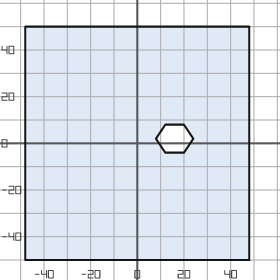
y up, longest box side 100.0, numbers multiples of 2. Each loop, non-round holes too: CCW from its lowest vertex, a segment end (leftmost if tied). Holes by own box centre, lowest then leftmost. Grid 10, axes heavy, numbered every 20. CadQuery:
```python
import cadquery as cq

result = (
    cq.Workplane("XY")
    .moveTo(-48.0, -50.0)
    .lineTo(48.0, -50.0)
    .lineTo(48.0, 50.0)
    .lineTo(-48.0, 50.0)
    .close()
    .moveTo(12.0, -4.0)
    .lineTo(20.0, -4.0)
    .lineTo(24.0, 2.0)
    .lineTo(20.0, 8.0)
    .lineTo(12.0, 8.0)
    .lineTo(8.0, 2.0)
    .close()
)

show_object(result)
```